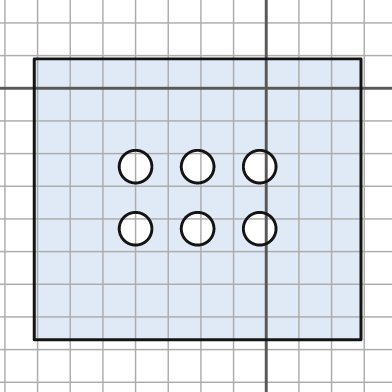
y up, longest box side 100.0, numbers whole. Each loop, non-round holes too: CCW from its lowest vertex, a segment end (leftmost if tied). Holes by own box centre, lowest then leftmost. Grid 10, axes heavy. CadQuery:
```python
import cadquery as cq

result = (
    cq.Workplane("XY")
    .moveTo(-71.0, -77.0)
    .lineTo(29.0, -77.0)
    .lineTo(29.0, 9.0)
    .lineTo(-71.0, 9.0)
    .close()
    .moveTo(-40.0, -43.0)
    .circle(5.0)
    .moveTo(-21.0, -43.0)
    .circle(5.0)
    .moveTo(-2.0, -43.0)
    .circle(5.0)
    .moveTo(-40.0, -24.0)
    .circle(5.0)
    .moveTo(-21.0, -24.0)
    .circle(5.0)
    .moveTo(-2.0, -24.0)
    .circle(5.0)
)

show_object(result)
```